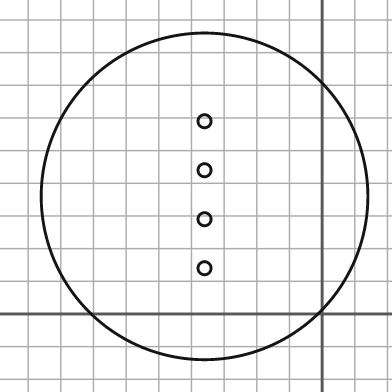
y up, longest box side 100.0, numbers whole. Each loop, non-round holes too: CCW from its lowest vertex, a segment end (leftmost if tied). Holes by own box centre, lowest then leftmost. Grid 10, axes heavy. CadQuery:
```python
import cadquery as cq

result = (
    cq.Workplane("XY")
    .moveTo(-36.0, 36.0)
    .circle(50.0)
    .moveTo(-36.0, 14.0)
    .circle(2.0)
    .moveTo(-36.0, 29.0)
    .circle(2.0)
    .moveTo(-36.0, 44.0)
    .circle(2.0)
    .moveTo(-36.0, 59.0)
    .circle(2.0)
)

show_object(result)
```